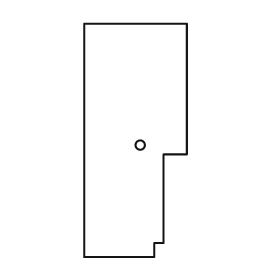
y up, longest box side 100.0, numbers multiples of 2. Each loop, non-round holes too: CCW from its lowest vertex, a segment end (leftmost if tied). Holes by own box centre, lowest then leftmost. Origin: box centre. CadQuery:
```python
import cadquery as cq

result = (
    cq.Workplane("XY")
    .moveTo(-22.0, -50.0)
    .lineTo(8.0, -50.0)
    .lineTo(8.0, -44.0)
    .lineTo(12.0, -44.0)
    .lineTo(12.0, -6.0)
    .lineTo(22.0, -6.0)
    .lineTo(22.0, 50.0)
    .lineTo(-22.0, 50.0)
    .close()
    .moveTo(2.0, -2.0)
    .circle(2.0)
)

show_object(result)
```